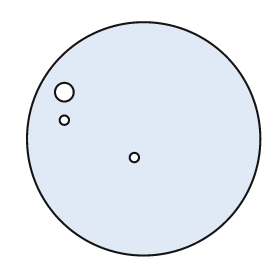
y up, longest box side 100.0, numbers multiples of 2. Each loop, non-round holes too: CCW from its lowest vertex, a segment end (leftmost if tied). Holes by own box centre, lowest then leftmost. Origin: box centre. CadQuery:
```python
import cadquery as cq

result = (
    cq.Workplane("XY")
    .moveTo(0.0, 0.0)
    .circle(50.0)
    .moveTo(-4.0, -8.0)
    .circle(2.0)
    .moveTo(-34.0, 8.0)
    .circle(2.0)
    .moveTo(-34.0, 20.0)
    .circle(4.0)
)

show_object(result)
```